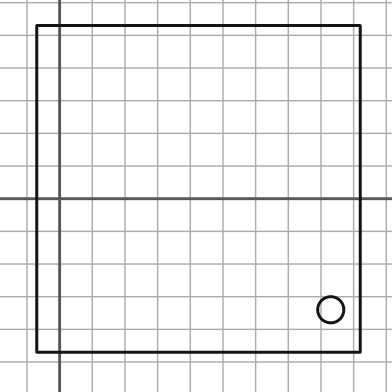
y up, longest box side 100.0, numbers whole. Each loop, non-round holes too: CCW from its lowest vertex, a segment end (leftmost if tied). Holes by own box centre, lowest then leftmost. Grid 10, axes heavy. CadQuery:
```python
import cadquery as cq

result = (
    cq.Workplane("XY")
    .moveTo(-7.0, -47.0)
    .lineTo(92.0, -47.0)
    .lineTo(92.0, 53.0)
    .lineTo(-7.0, 53.0)
    .close()
    .moveTo(83.0, -34.0)
    .circle(4.0)
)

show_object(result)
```